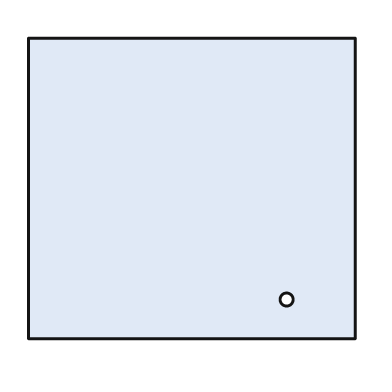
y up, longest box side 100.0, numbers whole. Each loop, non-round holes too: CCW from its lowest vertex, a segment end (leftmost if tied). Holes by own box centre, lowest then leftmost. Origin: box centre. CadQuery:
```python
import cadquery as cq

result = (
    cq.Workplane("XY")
    .moveTo(-50.0, -46.0)
    .lineTo(50.0, -46.0)
    .lineTo(50.0, 46.0)
    .lineTo(-50.0, 46.0)
    .close()
    .moveTo(29.0, -34.0)
    .circle(2.0)
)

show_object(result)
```